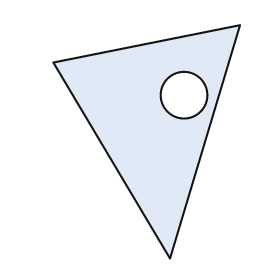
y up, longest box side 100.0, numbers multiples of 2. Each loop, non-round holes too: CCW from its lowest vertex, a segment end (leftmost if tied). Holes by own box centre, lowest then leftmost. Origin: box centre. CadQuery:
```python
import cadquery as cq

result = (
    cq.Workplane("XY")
    .moveTo(10.0, -50.0)
    .lineTo(40.0, 50.0)
    .lineTo(-40.0, 34.0)
    .close()
    .moveTo(16.0, 20.0)
    .circle(10.0)
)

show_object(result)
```